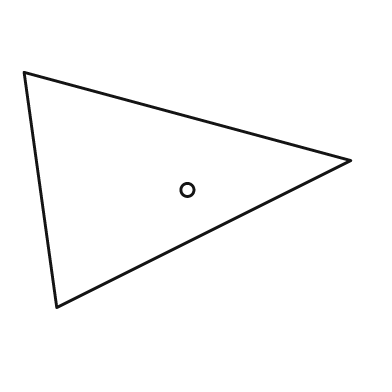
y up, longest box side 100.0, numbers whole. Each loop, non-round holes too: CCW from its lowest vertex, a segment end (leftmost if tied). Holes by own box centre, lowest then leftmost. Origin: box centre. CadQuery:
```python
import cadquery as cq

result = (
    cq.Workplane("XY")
    .moveTo(-40.0, -36.0)
    .lineTo(50.0, 9.0)
    .lineTo(-50.0, 36.0)
    .close()
    .moveTo(0.0, 0.0)
    .circle(2.0)
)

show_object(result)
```